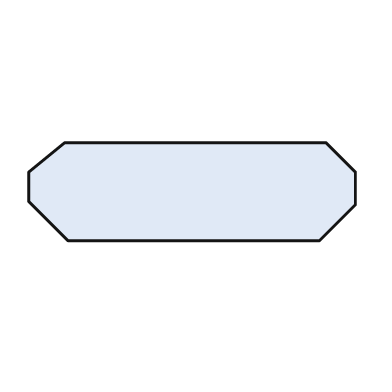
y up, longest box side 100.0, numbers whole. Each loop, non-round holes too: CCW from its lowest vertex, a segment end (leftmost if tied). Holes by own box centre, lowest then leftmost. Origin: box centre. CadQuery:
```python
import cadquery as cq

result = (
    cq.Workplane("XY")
    .moveTo(-38.0, -15.0)
    .lineTo(39.0, -15.0)
    .lineTo(50.0, -4.0)
    .lineTo(50.0, 6.0)
    .lineTo(41.0, 15.0)
    .lineTo(-39.0, 15.0)
    .lineTo(-50.0, 6.0)
    .lineTo(-50.0, -3.0)
    .close()
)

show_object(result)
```